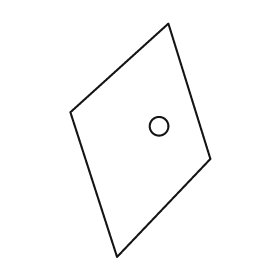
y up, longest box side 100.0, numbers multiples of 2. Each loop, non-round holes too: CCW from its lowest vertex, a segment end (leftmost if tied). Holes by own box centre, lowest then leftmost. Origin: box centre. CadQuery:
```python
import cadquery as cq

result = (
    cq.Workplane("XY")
    .moveTo(-10.0, -50.0)
    .lineTo(30.0, -8.0)
    .lineTo(12.0, 50.0)
    .lineTo(-30.0, 12.0)
    .close()
    .moveTo(8.0, 6.0)
    .circle(4.0)
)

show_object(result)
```